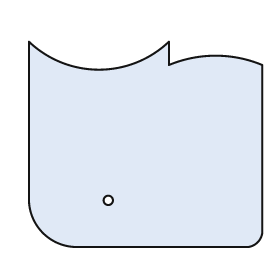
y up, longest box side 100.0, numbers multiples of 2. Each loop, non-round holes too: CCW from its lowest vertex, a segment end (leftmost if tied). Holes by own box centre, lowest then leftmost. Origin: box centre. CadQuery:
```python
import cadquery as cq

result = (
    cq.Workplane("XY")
    .moveTo(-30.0, -44.0)
    .lineTo(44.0, -44.0)
    .threePointArc((48.0, -42.0), (50.0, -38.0))
    .lineTo(50.0, 34.0)
    .threePointArc((30.0, 38.0), (10.0, 34.0))
    .lineTo(10.0, 44.0)
    .threePointArc((-20.0, 32.0), (-50.0, 44.0))
    .lineTo(-50.0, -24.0)
    .threePointArc((-44.0, -38.0), (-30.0, -44.0))
    .close()
    .moveTo(-16.0, -24.0)
    .circle(2.0)
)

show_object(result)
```